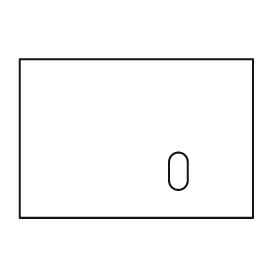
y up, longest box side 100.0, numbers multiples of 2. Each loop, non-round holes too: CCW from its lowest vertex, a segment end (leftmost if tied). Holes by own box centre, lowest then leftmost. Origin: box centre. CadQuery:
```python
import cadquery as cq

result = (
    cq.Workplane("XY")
    .moveTo(-50.0, -34.0)
    .lineTo(50.0, -34.0)
    .lineTo(50.0, 34.0)
    .lineTo(-50.0, 34.0)
    .close()
    .moveTo(14.0, -18.0)
    .threePointArc((18.0, -22.0), (22.0, -18.0))
    .lineTo(22.0, -10.0)
    .threePointArc((18.0, -6.0), (14.0, -10.0))
    .close()
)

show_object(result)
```